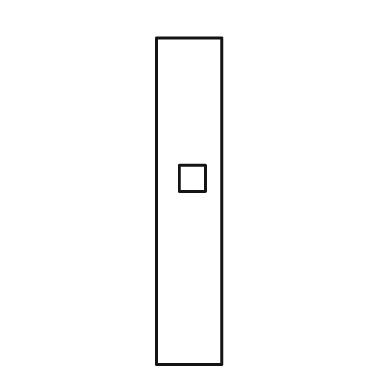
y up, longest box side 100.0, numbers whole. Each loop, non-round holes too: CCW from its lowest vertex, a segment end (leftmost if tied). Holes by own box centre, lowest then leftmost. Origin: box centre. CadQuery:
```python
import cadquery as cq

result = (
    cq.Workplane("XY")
    .moveTo(-10.0, -50.0)
    .lineTo(10.0, -50.0)
    .lineTo(10.0, 50.0)
    .lineTo(-10.0, 50.0)
    .close()
    .moveTo(-3.0, 3.0)
    .lineTo(5.0, 3.0)
    .lineTo(5.0, 11.0)
    .lineTo(-3.0, 11.0)
    .close()
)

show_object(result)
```